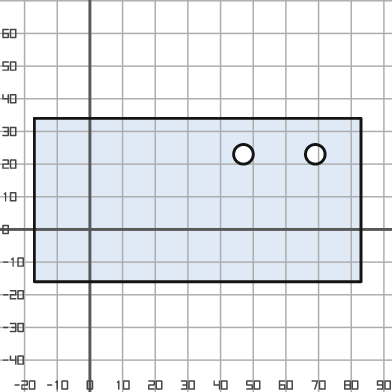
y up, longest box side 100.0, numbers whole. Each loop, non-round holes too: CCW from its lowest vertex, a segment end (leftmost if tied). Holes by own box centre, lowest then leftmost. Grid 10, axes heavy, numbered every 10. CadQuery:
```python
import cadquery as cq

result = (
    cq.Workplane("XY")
    .moveTo(-17.0, -16.0)
    .lineTo(83.0, -16.0)
    .lineTo(83.0, 34.0)
    .lineTo(-17.0, 34.0)
    .close()
    .moveTo(47.0, 23.0)
    .circle(3.0)
    .moveTo(69.0, 23.0)
    .circle(3.0)
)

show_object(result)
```